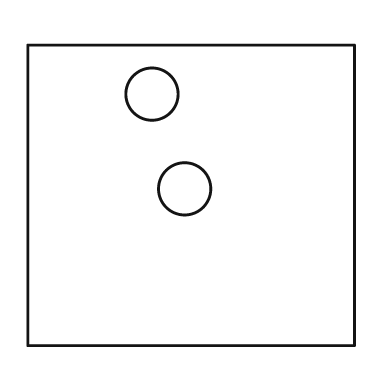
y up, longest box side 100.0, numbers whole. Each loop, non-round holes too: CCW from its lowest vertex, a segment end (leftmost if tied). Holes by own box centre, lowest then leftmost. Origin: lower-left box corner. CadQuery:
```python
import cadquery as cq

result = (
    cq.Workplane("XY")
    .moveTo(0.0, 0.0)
    .lineTo(100.0, 0.0)
    .lineTo(100.0, 92.0)
    .lineTo(0.0, 92.0)
    .close()
    .moveTo(48.0, 48.0)
    .circle(8.0)
    .moveTo(38.0, 77.0)
    .circle(8.0)
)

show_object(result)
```